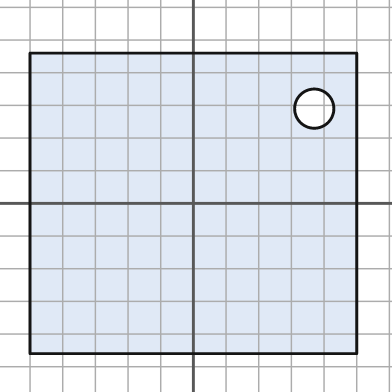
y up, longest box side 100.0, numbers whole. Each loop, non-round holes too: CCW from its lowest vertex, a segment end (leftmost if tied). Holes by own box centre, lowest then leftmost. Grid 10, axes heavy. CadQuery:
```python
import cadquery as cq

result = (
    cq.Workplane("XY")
    .moveTo(-50.0, -46.0)
    .lineTo(50.0, -46.0)
    .lineTo(50.0, 46.0)
    .lineTo(-50.0, 46.0)
    .close()
    .moveTo(37.0, 29.0)
    .circle(6.0)
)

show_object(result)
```